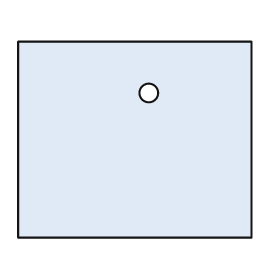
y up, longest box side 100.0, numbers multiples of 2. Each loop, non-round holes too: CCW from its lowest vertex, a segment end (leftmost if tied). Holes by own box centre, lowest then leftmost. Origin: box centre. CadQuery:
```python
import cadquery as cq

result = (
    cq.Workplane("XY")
    .moveTo(-50.0, -42.0)
    .lineTo(50.0, -42.0)
    .lineTo(50.0, 42.0)
    .lineTo(-50.0, 42.0)
    .close()
    .moveTo(6.0, 20.0)
    .circle(4.0)
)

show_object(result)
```